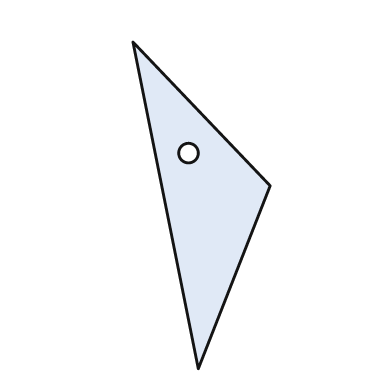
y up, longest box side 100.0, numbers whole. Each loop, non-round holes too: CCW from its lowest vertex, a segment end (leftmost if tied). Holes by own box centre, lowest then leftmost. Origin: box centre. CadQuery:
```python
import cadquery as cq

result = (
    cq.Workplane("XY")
    .moveTo(-1.0, -50.0)
    .lineTo(21.0, 6.0)
    .lineTo(-21.0, 50.0)
    .close()
    .moveTo(-4.0, 16.0)
    .circle(3.0)
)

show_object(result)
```